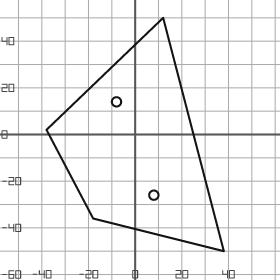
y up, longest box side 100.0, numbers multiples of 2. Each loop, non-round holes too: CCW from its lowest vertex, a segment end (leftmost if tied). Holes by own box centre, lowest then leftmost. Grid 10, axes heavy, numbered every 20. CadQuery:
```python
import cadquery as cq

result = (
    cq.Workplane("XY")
    .moveTo(38.0, -50.0)
    .lineTo(12.0, 50.0)
    .lineTo(-38.0, 2.0)
    .lineTo(-18.0, -36.0)
    .close()
    .moveTo(8.0, -26.0)
    .circle(2.0)
    .moveTo(-8.0, 14.0)
    .circle(2.0)
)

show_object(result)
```